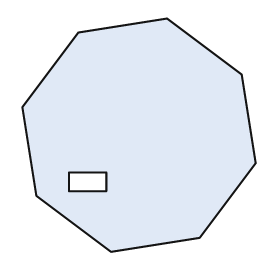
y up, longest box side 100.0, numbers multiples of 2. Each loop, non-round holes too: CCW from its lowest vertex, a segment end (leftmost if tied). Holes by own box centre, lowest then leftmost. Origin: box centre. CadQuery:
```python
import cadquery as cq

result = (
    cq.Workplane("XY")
    .moveTo(-12.0, -50.0)
    .lineTo(26.0, -44.0)
    .lineTo(50.0, -12.0)
    .lineTo(44.0, 26.0)
    .lineTo(12.0, 50.0)
    .lineTo(-26.0, 44.0)
    .lineTo(-50.0, 12.0)
    .lineTo(-44.0, -26.0)
    .close()
    .moveTo(-30.0, -24.0)
    .lineTo(-14.0, -24.0)
    .lineTo(-14.0, -16.0)
    .lineTo(-30.0, -16.0)
    .close()
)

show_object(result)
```